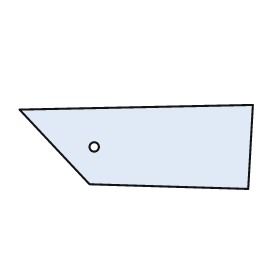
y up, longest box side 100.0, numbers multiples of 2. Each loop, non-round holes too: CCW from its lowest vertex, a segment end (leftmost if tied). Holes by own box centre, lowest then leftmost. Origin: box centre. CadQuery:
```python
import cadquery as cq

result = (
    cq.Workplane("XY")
    .moveTo(48.0, -18.0)
    .lineTo(50.0, 18.0)
    .lineTo(-50.0, 16.0)
    .lineTo(-20.0, -16.0)
    .close()
    .moveTo(-18.0, 0.0)
    .circle(2.0)
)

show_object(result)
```